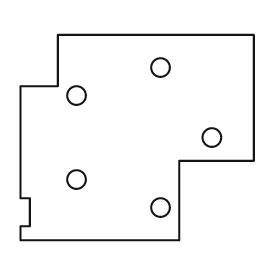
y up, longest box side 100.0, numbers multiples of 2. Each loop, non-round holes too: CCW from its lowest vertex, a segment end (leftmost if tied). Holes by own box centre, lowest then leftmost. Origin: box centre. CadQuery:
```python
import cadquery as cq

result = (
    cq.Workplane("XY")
    .moveTo(-50.0, -44.0)
    .lineTo(18.0, -44.0)
    .lineTo(18.0, -10.0)
    .lineTo(50.0, -10.0)
    .lineTo(50.0, 44.0)
    .lineTo(-34.0, 44.0)
    .lineTo(-34.0, 22.0)
    .lineTo(-50.0, 22.0)
    .lineTo(-50.0, -26.0)
    .lineTo(-46.0, -26.0)
    .lineTo(-46.0, -38.0)
    .lineTo(-50.0, -38.0)
    .close()
    .moveTo(10.0, -30.0)
    .circle(4.0)
    .moveTo(-26.0, -18.0)
    .circle(4.0)
    .moveTo(32.0, 0.0)
    .circle(4.0)
    .moveTo(-26.0, 18.0)
    .circle(4.0)
    .moveTo(10.0, 30.0)
    .circle(4.0)
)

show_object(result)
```